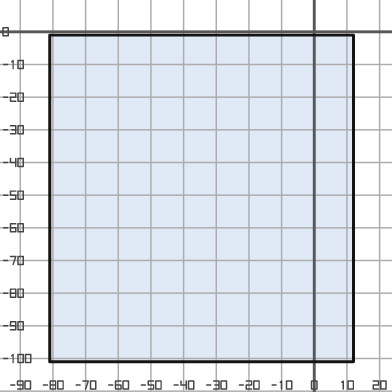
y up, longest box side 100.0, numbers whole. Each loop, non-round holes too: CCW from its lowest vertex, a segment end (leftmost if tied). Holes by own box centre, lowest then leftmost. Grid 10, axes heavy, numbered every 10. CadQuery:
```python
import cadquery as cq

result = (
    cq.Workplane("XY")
    .moveTo(-81.0, -101.0)
    .lineTo(12.0, -101.0)
    .lineTo(12.0, -1.0)
    .lineTo(-81.0, -1.0)
    .close()
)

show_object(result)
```